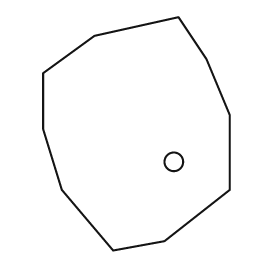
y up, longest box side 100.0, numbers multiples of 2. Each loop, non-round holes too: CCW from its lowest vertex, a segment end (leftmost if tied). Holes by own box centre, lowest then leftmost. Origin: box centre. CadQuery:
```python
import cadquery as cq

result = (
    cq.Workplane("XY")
    .moveTo(-10.0, -50.0)
    .lineTo(12.0, -46.0)
    .lineTo(40.0, -24.0)
    .lineTo(40.0, 8.0)
    .lineTo(30.0, 32.0)
    .lineTo(18.0, 50.0)
    .lineTo(-18.0, 42.0)
    .lineTo(-40.0, 26.0)
    .lineTo(-40.0, 2.0)
    .lineTo(-32.0, -24.0)
    .close()
    .moveTo(16.0, -12.0)
    .circle(4.0)
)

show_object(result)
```